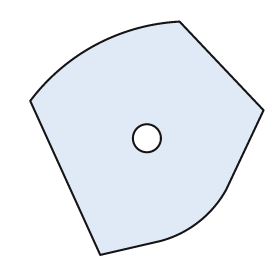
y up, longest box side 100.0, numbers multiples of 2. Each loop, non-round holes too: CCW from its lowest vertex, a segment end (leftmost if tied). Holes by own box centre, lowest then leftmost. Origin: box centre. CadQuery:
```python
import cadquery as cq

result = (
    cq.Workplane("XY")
    .moveTo(-20.0, -50.0)
    .lineTo(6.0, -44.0)
    .threePointArc((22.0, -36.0), (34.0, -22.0))
    .lineTo(50.0, 12.0)
    .lineTo(14.0, 50.0)
    .threePointArc((-22.0, 40.0), (-50.0, 16.0))
    .close()
    .moveTo(0.0, 0.0)
    .circle(6.0)
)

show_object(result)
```